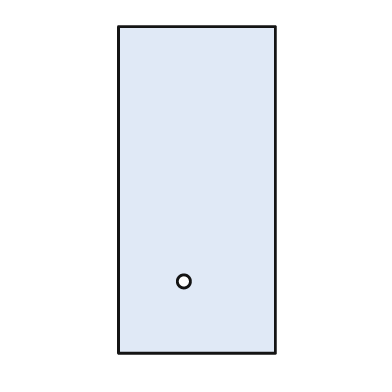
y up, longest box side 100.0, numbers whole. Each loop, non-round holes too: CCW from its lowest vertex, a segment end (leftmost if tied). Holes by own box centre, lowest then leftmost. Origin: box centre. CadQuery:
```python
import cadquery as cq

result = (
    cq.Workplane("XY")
    .moveTo(-24.0, -50.0)
    .lineTo(24.0, -50.0)
    .lineTo(24.0, 50.0)
    .lineTo(-24.0, 50.0)
    .close()
    .moveTo(-4.0, -28.0)
    .circle(2.0)
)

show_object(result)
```